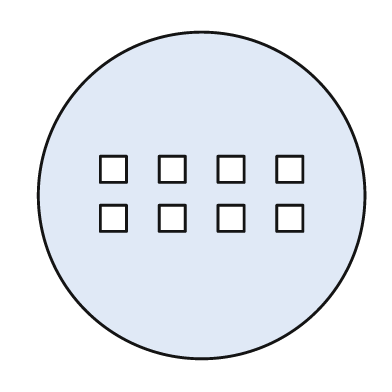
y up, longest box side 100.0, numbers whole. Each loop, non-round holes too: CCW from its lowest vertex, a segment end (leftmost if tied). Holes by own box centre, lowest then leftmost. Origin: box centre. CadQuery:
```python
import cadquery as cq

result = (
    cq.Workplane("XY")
    .moveTo(0.0, 0.0)
    .circle(50.0)
    .moveTo(-31.0, -11.0)
    .lineTo(-23.0, -11.0)
    .lineTo(-23.0, -3.0)
    .lineTo(-31.0, -3.0)
    .close()
    .moveTo(-13.0, -11.0)
    .lineTo(-5.0, -11.0)
    .lineTo(-5.0, -3.0)
    .lineTo(-13.0, -3.0)
    .close()
    .moveTo(5.0, -11.0)
    .lineTo(13.0, -11.0)
    .lineTo(13.0, -3.0)
    .lineTo(5.0, -3.0)
    .close()
    .moveTo(23.0, -11.0)
    .lineTo(31.0, -11.0)
    .lineTo(31.0, -3.0)
    .lineTo(23.0, -3.0)
    .close()
    .moveTo(-31.0, 4.0)
    .lineTo(-23.0, 4.0)
    .lineTo(-23.0, 12.0)
    .lineTo(-31.0, 12.0)
    .close()
    .moveTo(-13.0, 4.0)
    .lineTo(-5.0, 4.0)
    .lineTo(-5.0, 12.0)
    .lineTo(-13.0, 12.0)
    .close()
    .moveTo(5.0, 4.0)
    .lineTo(13.0, 4.0)
    .lineTo(13.0, 12.0)
    .lineTo(5.0, 12.0)
    .close()
    .moveTo(23.0, 4.0)
    .lineTo(31.0, 4.0)
    .lineTo(31.0, 12.0)
    .lineTo(23.0, 12.0)
    .close()
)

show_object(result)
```